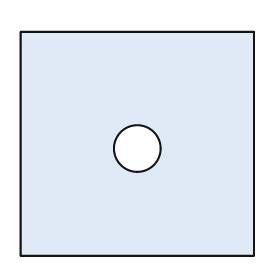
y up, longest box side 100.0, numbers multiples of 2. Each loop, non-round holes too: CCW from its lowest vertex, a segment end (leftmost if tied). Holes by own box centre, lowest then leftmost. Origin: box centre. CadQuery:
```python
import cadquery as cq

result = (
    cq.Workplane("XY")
    .moveTo(-50.0, -48.0)
    .lineTo(50.0, -48.0)
    .lineTo(50.0, 48.0)
    .lineTo(-50.0, 48.0)
    .close()
    .moveTo(0.0, -2.0)
    .circle(10.0)
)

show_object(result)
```